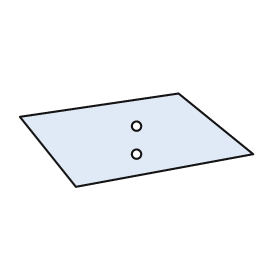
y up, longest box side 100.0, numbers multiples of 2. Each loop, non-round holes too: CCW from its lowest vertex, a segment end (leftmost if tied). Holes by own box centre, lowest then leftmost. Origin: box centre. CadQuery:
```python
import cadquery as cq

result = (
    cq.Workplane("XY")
    .moveTo(-26.0, -20.0)
    .lineTo(50.0, -6.0)
    .lineTo(18.0, 20.0)
    .lineTo(-50.0, 10.0)
    .close()
    .moveTo(0.0, -6.0)
    .circle(2.0)
    .moveTo(0.0, 6.0)
    .circle(2.0)
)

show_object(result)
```